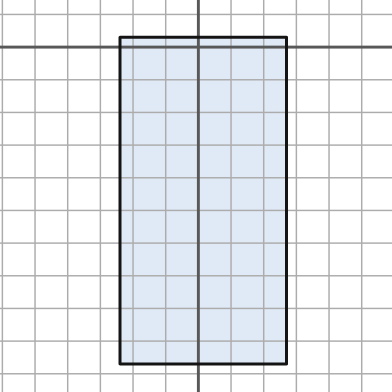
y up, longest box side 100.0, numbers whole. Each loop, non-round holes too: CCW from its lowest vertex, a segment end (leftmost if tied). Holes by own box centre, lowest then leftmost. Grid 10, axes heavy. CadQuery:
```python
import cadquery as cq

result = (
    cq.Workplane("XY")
    .moveTo(-24.0, -97.0)
    .lineTo(27.0, -97.0)
    .lineTo(27.0, 3.0)
    .lineTo(-24.0, 3.0)
    .close()
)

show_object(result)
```